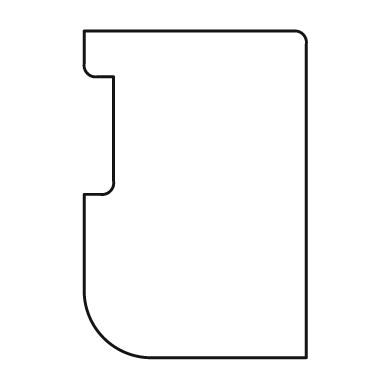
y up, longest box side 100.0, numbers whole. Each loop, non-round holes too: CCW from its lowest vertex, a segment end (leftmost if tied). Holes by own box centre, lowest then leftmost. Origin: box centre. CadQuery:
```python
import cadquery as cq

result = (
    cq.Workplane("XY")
    .moveTo(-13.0, -50.0)
    .lineTo(34.0, -50.0)
    .lineTo(34.0, 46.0)
    .threePointArc((33.0, 49.0), (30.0, 50.0))
    .lineTo(-34.0, 50.0)
    .lineTo(-34.0, 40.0)
    .threePointArc((-33.0, 37.0), (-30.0, 36.0))
    .lineTo(-25.0, 36.0)
    .lineTo(-25.0, 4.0)
    .threePointArc((-26.0, 1.0), (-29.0, 0.0))
    .lineTo(-34.0, 0.0)
    .lineTo(-34.0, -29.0)
    .threePointArc((-28.0, -44.0), (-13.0, -50.0))
    .close()
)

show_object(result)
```